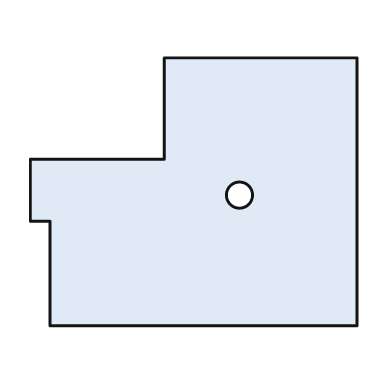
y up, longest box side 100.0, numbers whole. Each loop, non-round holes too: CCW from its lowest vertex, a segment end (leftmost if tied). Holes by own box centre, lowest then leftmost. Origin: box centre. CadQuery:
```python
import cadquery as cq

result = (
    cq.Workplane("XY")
    .moveTo(-44.0, -41.0)
    .lineTo(50.0, -41.0)
    .lineTo(50.0, 41.0)
    .lineTo(-9.0, 41.0)
    .lineTo(-9.0, 10.0)
    .lineTo(-50.0, 10.0)
    .lineTo(-50.0, -9.0)
    .lineTo(-44.0, -9.0)
    .close()
    .moveTo(14.0, -1.0)
    .circle(4.0)
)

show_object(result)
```